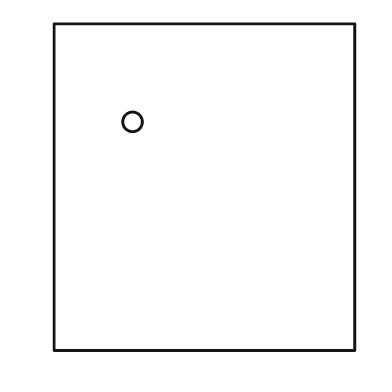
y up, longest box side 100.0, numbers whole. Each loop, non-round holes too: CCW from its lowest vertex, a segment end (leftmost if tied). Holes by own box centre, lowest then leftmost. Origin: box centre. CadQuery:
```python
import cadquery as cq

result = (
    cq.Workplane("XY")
    .moveTo(-46.0, -50.0)
    .lineTo(46.0, -50.0)
    .lineTo(46.0, 50.0)
    .lineTo(-46.0, 50.0)
    .close()
    .moveTo(-22.0, 20.0)
    .circle(3.0)
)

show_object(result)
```